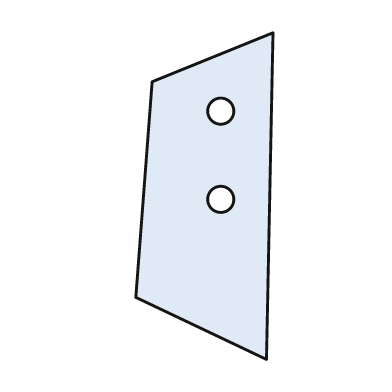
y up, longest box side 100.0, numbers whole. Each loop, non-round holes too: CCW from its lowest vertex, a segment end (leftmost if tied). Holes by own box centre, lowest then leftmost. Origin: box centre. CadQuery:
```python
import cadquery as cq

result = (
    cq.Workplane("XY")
    .moveTo(19.0, -50.0)
    .lineTo(21.0, 50.0)
    .lineTo(-16.0, 35.0)
    .lineTo(-21.0, -31.0)
    .close()
    .moveTo(5.0, -1.0)
    .circle(4.0)
    .moveTo(5.0, 26.0)
    .circle(4.0)
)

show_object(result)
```